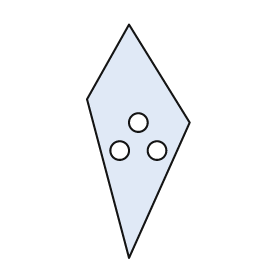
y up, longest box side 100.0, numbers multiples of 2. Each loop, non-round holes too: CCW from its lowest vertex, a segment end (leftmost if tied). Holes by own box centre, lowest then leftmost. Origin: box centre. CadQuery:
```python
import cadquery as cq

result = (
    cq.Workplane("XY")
    .moveTo(-4.0, -50.0)
    .lineTo(22.0, 8.0)
    .lineTo(-4.0, 50.0)
    .lineTo(-22.0, 18.0)
    .close()
    .moveTo(-8.0, -4.0)
    .circle(4.0)
    .moveTo(8.0, -4.0)
    .circle(4.0)
    .moveTo(0.0, 8.0)
    .circle(4.0)
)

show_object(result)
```